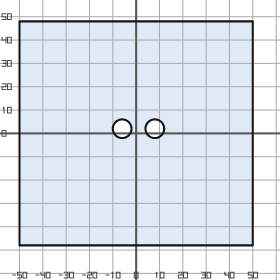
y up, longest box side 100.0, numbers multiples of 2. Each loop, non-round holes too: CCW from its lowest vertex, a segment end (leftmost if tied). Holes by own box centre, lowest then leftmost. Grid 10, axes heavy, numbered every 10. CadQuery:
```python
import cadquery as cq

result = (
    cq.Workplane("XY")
    .moveTo(-50.0, -48.0)
    .lineTo(50.0, -48.0)
    .lineTo(50.0, 48.0)
    .lineTo(-50.0, 48.0)
    .close()
    .moveTo(-6.0, 2.0)
    .circle(4.0)
    .moveTo(8.0, 2.0)
    .circle(4.0)
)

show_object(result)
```